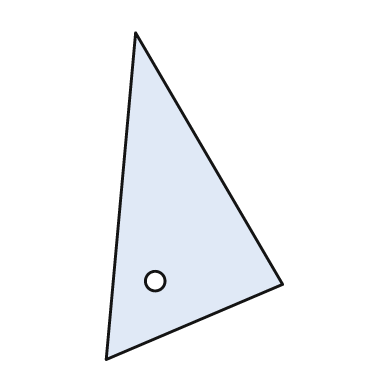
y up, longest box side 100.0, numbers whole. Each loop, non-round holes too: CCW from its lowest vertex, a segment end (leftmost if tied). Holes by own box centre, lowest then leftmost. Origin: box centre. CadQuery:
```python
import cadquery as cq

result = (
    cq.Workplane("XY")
    .moveTo(-27.0, -50.0)
    .lineTo(27.0, -27.0)
    .lineTo(-18.0, 50.0)
    .close()
    .moveTo(-12.0, -26.0)
    .circle(3.0)
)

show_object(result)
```